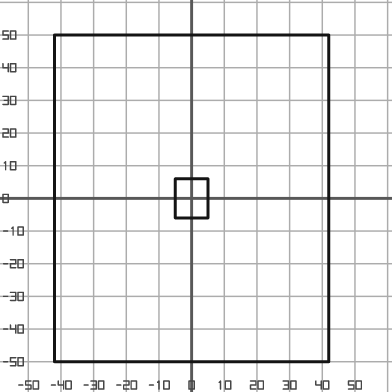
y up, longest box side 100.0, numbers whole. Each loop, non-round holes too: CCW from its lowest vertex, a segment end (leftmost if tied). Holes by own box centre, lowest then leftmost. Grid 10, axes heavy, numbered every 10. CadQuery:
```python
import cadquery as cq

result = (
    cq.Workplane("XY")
    .moveTo(-42.0, -50.0)
    .lineTo(42.0, -50.0)
    .lineTo(42.0, 50.0)
    .lineTo(-42.0, 50.0)
    .close()
    .moveTo(-5.0, -6.0)
    .lineTo(5.0, -6.0)
    .lineTo(5.0, 6.0)
    .lineTo(-5.0, 6.0)
    .close()
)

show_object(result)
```